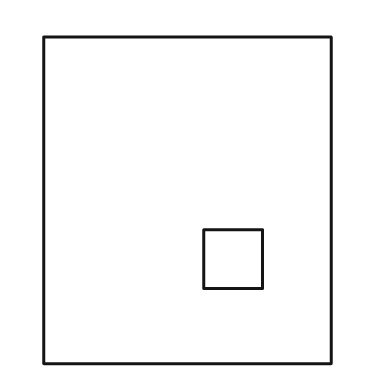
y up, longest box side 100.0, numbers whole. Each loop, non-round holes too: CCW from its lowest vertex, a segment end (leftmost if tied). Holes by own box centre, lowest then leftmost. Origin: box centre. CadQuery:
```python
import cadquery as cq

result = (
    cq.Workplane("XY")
    .moveTo(-44.0, -50.0)
    .lineTo(44.0, -50.0)
    .lineTo(44.0, 50.0)
    .lineTo(-44.0, 50.0)
    .close()
    .moveTo(5.0, -27.0)
    .lineTo(23.0, -27.0)
    .lineTo(23.0, -9.0)
    .lineTo(5.0, -9.0)
    .close()
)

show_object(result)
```